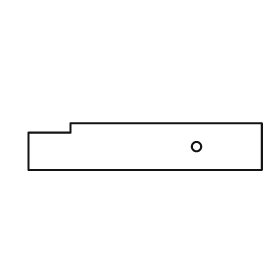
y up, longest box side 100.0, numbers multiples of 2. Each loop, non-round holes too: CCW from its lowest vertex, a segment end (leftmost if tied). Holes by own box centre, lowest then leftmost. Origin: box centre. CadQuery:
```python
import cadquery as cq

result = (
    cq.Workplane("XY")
    .moveTo(-50.0, -10.0)
    .lineTo(50.0, -10.0)
    .lineTo(50.0, 10.0)
    .lineTo(-32.0, 10.0)
    .lineTo(-32.0, 6.0)
    .lineTo(-50.0, 6.0)
    .close()
    .moveTo(22.0, 0.0)
    .circle(2.0)
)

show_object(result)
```